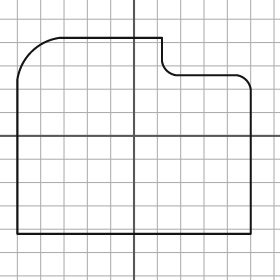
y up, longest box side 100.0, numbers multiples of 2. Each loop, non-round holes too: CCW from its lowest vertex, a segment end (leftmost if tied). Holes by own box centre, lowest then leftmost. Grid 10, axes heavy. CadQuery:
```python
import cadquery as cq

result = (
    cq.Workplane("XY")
    .moveTo(-50.0, -42.0)
    .lineTo(50.0, -42.0)
    .lineTo(50.0, 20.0)
    .threePointArc((48.0, 24.0), (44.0, 26.0))
    .lineTo(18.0, 26.0)
    .threePointArc((14.0, 28.0), (12.0, 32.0))
    .lineTo(12.0, 42.0)
    .lineTo(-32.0, 42.0)
    .threePointArc((-44.0, 36.0), (-50.0, 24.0))
    .close()
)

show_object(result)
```